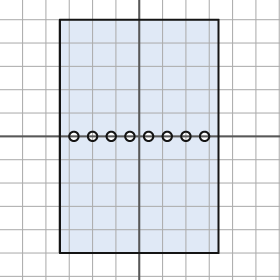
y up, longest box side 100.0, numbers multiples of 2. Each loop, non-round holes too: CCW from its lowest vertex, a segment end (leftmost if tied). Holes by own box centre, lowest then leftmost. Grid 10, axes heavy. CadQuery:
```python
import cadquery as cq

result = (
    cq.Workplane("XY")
    .moveTo(-34.0, -50.0)
    .lineTo(34.0, -50.0)
    .lineTo(34.0, 50.0)
    .lineTo(-34.0, 50.0)
    .close()
    .moveTo(-28.0, 0.0)
    .circle(2.0)
    .moveTo(-20.0, 0.0)
    .circle(2.0)
    .moveTo(-12.0, 0.0)
    .circle(2.0)
    .moveTo(-4.0, 0.0)
    .circle(2.0)
    .moveTo(4.0, 0.0)
    .circle(2.0)
    .moveTo(12.0, 0.0)
    .circle(2.0)
    .moveTo(20.0, 0.0)
    .circle(2.0)
    .moveTo(28.0, 0.0)
    .circle(2.0)
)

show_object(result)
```